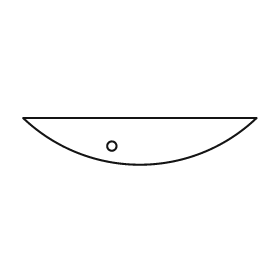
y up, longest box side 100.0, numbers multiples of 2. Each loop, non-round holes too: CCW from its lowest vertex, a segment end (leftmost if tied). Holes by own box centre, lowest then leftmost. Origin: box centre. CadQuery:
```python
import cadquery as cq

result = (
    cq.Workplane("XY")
    .moveTo(-50.0, 10.0)
    .threePointArc((0.0, -10.0), (50.0, 10.0))
    .close()
    .moveTo(-12.0, -2.0)
    .circle(2.0)
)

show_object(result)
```